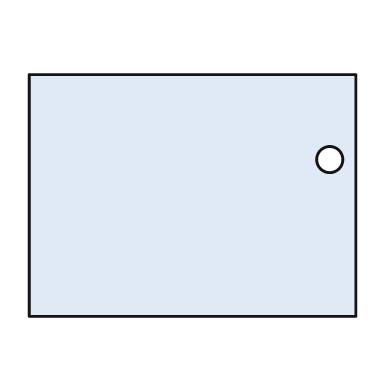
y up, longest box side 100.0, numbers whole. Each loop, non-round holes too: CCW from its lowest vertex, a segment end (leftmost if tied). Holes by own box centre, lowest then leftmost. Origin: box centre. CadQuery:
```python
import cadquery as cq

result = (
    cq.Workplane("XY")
    .moveTo(-50.0, -37.0)
    .lineTo(50.0, -37.0)
    .lineTo(50.0, 37.0)
    .lineTo(-50.0, 37.0)
    .close()
    .moveTo(42.0, 11.0)
    .circle(4.0)
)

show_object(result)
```